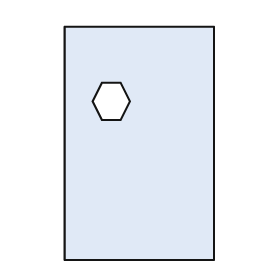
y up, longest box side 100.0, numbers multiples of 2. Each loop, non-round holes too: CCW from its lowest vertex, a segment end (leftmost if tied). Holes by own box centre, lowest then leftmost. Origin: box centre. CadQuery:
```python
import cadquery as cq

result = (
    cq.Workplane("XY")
    .moveTo(-32.0, -50.0)
    .lineTo(32.0, -50.0)
    .lineTo(32.0, 50.0)
    .lineTo(-32.0, 50.0)
    .close()
    .moveTo(-16.0, 10.0)
    .lineTo(-8.0, 10.0)
    .lineTo(-4.0, 18.0)
    .lineTo(-8.0, 26.0)
    .lineTo(-16.0, 26.0)
    .lineTo(-20.0, 18.0)
    .close()
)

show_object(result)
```